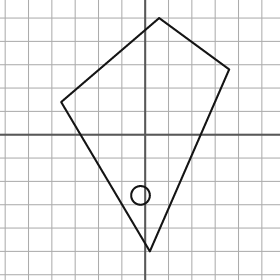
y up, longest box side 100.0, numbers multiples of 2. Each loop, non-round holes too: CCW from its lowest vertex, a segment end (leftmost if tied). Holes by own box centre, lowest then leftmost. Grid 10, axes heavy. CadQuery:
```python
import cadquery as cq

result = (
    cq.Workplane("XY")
    .moveTo(2.0, -50.0)
    .lineTo(36.0, 28.0)
    .lineTo(6.0, 50.0)
    .lineTo(-36.0, 14.0)
    .close()
    .moveTo(-2.0, -26.0)
    .circle(4.0)
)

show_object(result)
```